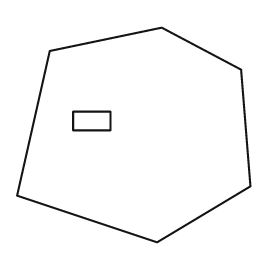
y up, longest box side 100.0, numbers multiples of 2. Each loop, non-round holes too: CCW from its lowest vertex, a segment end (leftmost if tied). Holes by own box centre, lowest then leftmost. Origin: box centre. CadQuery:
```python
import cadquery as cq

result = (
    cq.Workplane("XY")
    .moveTo(10.0, -46.0)
    .lineTo(50.0, -22.0)
    .lineTo(46.0, 28.0)
    .lineTo(12.0, 46.0)
    .lineTo(-36.0, 36.0)
    .lineTo(-50.0, -26.0)
    .close()
    .moveTo(-26.0, 2.0)
    .lineTo(-10.0, 2.0)
    .lineTo(-10.0, 10.0)
    .lineTo(-26.0, 10.0)
    .close()
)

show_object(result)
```